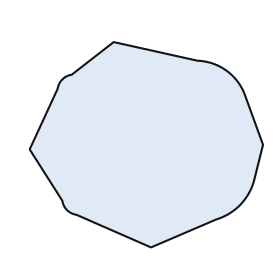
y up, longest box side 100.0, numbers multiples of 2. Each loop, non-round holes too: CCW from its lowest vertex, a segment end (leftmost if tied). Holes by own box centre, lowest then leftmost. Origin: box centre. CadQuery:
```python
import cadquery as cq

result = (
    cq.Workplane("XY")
    .moveTo(2.0, -44.0)
    .lineTo(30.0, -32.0)
    .threePointArc((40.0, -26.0), (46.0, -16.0))
    .lineTo(50.0, 0.0)
    .lineTo(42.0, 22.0)
    .threePointArc((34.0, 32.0), (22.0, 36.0))
    .lineTo(-14.0, 44.0)
    .lineTo(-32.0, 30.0)
    .threePointArc((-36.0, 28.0), (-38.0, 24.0))
    .lineTo(-50.0, -2.0)
    .lineTo(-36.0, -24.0)
    .threePointArc((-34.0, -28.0), (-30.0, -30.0))
    .close()
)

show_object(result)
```